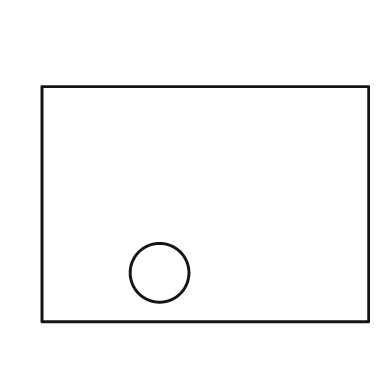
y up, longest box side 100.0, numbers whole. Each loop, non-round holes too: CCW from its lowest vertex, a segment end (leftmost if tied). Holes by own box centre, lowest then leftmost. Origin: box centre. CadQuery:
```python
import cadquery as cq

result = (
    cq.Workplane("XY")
    .moveTo(-50.0, -36.0)
    .lineTo(50.0, -36.0)
    .lineTo(50.0, 36.0)
    .lineTo(-50.0, 36.0)
    .close()
    .moveTo(-14.0, -21.0)
    .circle(9.0)
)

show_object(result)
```